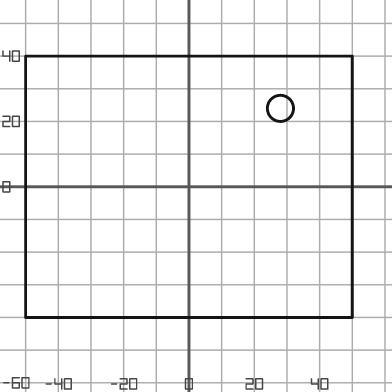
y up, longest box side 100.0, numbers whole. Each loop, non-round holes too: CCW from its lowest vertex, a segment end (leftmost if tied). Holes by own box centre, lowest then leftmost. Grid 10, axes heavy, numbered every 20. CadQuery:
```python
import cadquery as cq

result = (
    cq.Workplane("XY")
    .moveTo(-50.0, -40.0)
    .lineTo(50.0, -40.0)
    .lineTo(50.0, 40.0)
    .lineTo(-50.0, 40.0)
    .close()
    .moveTo(28.0, 24.0)
    .circle(4.0)
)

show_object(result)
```